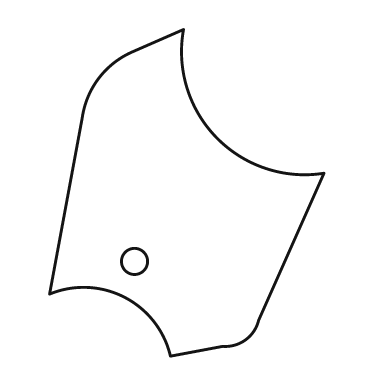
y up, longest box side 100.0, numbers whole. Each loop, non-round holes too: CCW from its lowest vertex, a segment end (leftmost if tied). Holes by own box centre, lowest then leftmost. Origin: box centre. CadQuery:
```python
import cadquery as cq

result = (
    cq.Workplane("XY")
    .moveTo(-5.0, -50.0)
    .lineTo(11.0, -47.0)
    .threePointArc((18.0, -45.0), (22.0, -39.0))
    .lineTo(42.0, 6.0)
    .threePointArc((9.0, 17.0), (-1.0, 50.0))
    .lineTo(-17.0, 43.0)
    .threePointArc((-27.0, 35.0), (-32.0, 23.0))
    .lineTo(-42.0, -31.0)
    .threePointArc((-19.0, -32.0), (-5.0, -50.0))
    .close()
    .moveTo(-16.0, -21.0)
    .circle(4.0)
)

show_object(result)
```